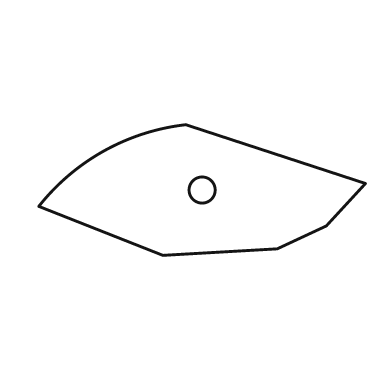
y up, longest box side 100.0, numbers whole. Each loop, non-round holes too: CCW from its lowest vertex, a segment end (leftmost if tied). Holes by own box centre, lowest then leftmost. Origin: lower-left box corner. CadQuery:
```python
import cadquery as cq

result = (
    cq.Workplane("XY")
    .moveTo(38.0, 0.0)
    .lineTo(73.0, 2.0)
    .lineTo(88.0, 9.0)
    .lineTo(100.0, 22.0)
    .lineTo(45.0, 40.0)
    .threePointArc((20.0, 32.0), (0.0, 15.0))
    .close()
    .moveTo(50.0, 20.0)
    .circle(4.0)
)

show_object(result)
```